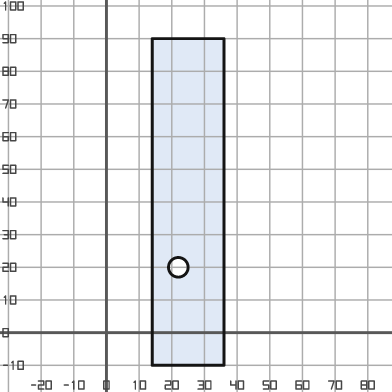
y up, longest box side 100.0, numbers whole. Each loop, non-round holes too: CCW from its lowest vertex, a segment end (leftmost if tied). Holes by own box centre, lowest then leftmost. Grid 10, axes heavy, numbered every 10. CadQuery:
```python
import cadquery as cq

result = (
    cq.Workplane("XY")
    .moveTo(14.0, -10.0)
    .lineTo(36.0, -10.0)
    .lineTo(36.0, 90.0)
    .lineTo(14.0, 90.0)
    .close()
    .moveTo(22.0, 20.0)
    .circle(3.0)
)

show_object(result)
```